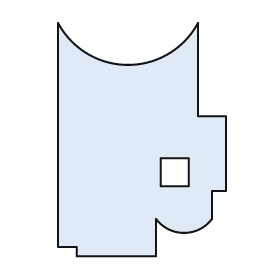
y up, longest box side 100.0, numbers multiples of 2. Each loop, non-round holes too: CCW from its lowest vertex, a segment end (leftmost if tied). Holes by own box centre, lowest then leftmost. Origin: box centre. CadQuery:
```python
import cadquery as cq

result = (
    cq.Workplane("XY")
    .moveTo(-28.0, -50.0)
    .lineTo(6.0, -50.0)
    .lineTo(6.0, -34.0)
    .threePointArc((18.0, -40.0), (30.0, -34.0))
    .lineTo(30.0, -22.0)
    .lineTo(36.0, -22.0)
    .lineTo(36.0, 10.0)
    .lineTo(24.0, 10.0)
    .lineTo(24.0, 50.0)
    .threePointArc((-6.0, 32.0), (-36.0, 50.0))
    .lineTo(-36.0, -46.0)
    .lineTo(-28.0, -46.0)
    .close()
    .moveTo(8.0, -20.0)
    .lineTo(20.0, -20.0)
    .lineTo(20.0, -8.0)
    .lineTo(8.0, -8.0)
    .close()
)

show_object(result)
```